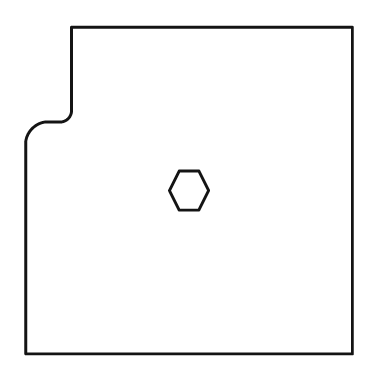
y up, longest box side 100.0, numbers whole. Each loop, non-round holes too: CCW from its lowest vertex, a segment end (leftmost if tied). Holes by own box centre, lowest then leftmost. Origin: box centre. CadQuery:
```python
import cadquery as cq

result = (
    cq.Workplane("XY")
    .moveTo(-50.0, -50.0)
    .lineTo(50.0, -50.0)
    .lineTo(50.0, 50.0)
    .lineTo(-36.0, 50.0)
    .lineTo(-36.0, 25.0)
    .threePointArc((-37.0, 22.0), (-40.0, 21.0))
    .lineTo(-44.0, 21.0)
    .threePointArc((-48.0, 19.0), (-50.0, 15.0))
    .close()
    .moveTo(-3.0, -6.0)
    .lineTo(3.0, -6.0)
    .lineTo(6.0, 0.0)
    .lineTo(3.0, 6.0)
    .lineTo(-3.0, 6.0)
    .lineTo(-6.0, 0.0)
    .close()
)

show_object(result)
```